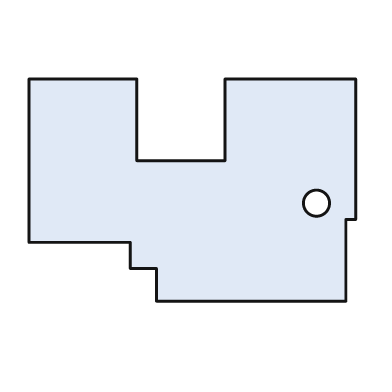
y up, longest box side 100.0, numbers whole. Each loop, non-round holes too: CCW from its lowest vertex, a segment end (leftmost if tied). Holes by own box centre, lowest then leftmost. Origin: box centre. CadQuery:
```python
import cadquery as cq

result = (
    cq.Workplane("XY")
    .moveTo(-11.0, -34.0)
    .lineTo(47.0, -34.0)
    .lineTo(47.0, -9.0)
    .lineTo(50.0, -9.0)
    .lineTo(50.0, 34.0)
    .lineTo(10.0, 34.0)
    .lineTo(10.0, 9.0)
    .lineTo(-17.0, 9.0)
    .lineTo(-17.0, 34.0)
    .lineTo(-50.0, 34.0)
    .lineTo(-50.0, -16.0)
    .lineTo(-19.0, -16.0)
    .lineTo(-19.0, -24.0)
    .lineTo(-11.0, -24.0)
    .close()
    .moveTo(38.0, -4.0)
    .circle(4.0)
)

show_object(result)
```